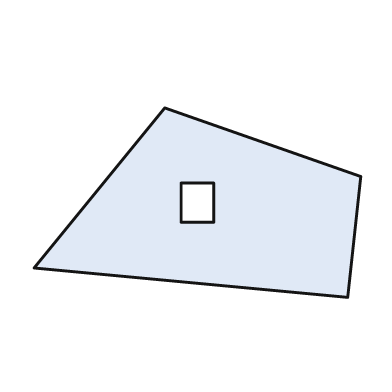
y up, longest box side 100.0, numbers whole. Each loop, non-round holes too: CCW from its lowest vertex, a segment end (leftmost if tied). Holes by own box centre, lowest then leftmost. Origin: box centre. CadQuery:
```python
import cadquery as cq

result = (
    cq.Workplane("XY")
    .moveTo(46.0, -29.0)
    .lineTo(50.0, 8.0)
    .lineTo(-10.0, 29.0)
    .lineTo(-50.0, -20.0)
    .close()
    .moveTo(-5.0, -6.0)
    .lineTo(5.0, -6.0)
    .lineTo(5.0, 6.0)
    .lineTo(-5.0, 6.0)
    .close()
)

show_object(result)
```